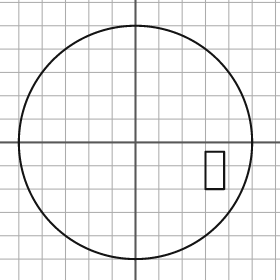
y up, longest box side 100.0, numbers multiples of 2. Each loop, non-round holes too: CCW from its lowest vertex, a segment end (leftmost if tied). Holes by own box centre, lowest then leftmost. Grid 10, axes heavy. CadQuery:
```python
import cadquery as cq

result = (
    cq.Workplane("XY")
    .moveTo(0.0, 0.0)
    .circle(50.0)
    .moveTo(30.0, -20.0)
    .lineTo(38.0, -20.0)
    .lineTo(38.0, -4.0)
    .lineTo(30.0, -4.0)
    .close()
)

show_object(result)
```